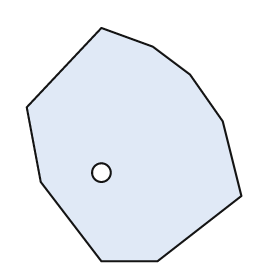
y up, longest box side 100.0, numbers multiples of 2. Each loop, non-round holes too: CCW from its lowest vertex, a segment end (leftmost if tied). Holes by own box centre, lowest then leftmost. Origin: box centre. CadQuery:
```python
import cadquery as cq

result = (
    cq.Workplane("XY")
    .moveTo(-14.0, -50.0)
    .lineTo(10.0, -50.0)
    .lineTo(46.0, -22.0)
    .lineTo(38.0, 10.0)
    .lineTo(24.0, 30.0)
    .lineTo(8.0, 42.0)
    .lineTo(-14.0, 50.0)
    .lineTo(-46.0, 16.0)
    .lineTo(-40.0, -16.0)
    .close()
    .moveTo(-14.0, -12.0)
    .circle(4.0)
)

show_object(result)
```